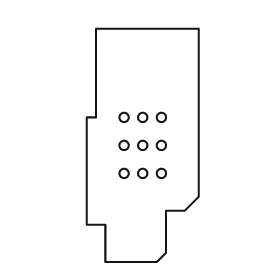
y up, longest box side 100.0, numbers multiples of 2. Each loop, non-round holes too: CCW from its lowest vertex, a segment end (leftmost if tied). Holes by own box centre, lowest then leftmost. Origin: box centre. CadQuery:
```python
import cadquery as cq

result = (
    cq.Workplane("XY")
    .moveTo(-16.0, -50.0)
    .lineTo(6.0, -50.0)
    .lineTo(10.0, -46.0)
    .lineTo(10.0, -28.0)
    .lineTo(18.0, -28.0)
    .lineTo(24.0, -22.0)
    .lineTo(24.0, 50.0)
    .lineTo(-20.0, 50.0)
    .lineTo(-20.0, 12.0)
    .lineTo(-24.0, 12.0)
    .lineTo(-24.0, -34.0)
    .lineTo(-16.0, -34.0)
    .close()
    .moveTo(-8.0, -12.0)
    .circle(2.0)
    .moveTo(0.0, -12.0)
    .circle(2.0)
    .moveTo(8.0, -12.0)
    .circle(2.0)
    .moveTo(-8.0, 0.0)
    .circle(2.0)
    .moveTo(0.0, 0.0)
    .circle(2.0)
    .moveTo(8.0, 0.0)
    .circle(2.0)
    .moveTo(-8.0, 12.0)
    .circle(2.0)
    .moveTo(0.0, 12.0)
    .circle(2.0)
    .moveTo(8.0, 12.0)
    .circle(2.0)
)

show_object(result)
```